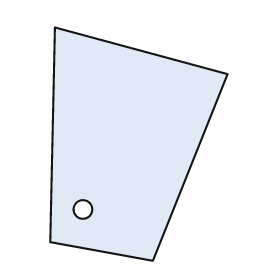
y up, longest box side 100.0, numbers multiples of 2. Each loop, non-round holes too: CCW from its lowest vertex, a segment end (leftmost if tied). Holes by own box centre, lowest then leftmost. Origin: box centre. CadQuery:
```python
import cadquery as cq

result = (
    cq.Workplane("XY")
    .moveTo(6.0, -50.0)
    .lineTo(38.0, 30.0)
    .lineTo(-36.0, 50.0)
    .lineTo(-38.0, -42.0)
    .close()
    .moveTo(-24.0, -28.0)
    .circle(4.0)
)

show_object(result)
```